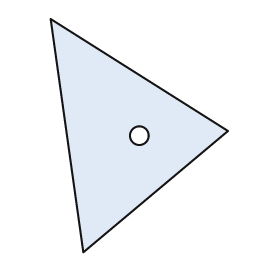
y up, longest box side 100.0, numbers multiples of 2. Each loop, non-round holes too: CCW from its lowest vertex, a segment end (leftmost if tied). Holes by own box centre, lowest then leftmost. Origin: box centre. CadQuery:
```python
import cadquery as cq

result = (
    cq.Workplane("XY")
    .moveTo(-24.0, -50.0)
    .lineTo(38.0, 2.0)
    .lineTo(-38.0, 50.0)
    .close()
    .moveTo(0.0, 0.0)
    .circle(4.0)
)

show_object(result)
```